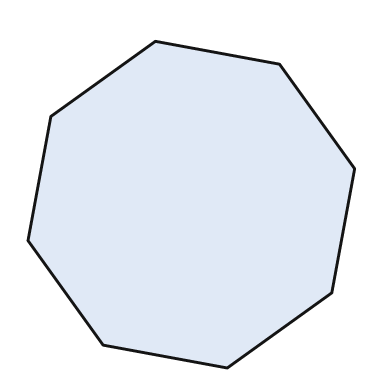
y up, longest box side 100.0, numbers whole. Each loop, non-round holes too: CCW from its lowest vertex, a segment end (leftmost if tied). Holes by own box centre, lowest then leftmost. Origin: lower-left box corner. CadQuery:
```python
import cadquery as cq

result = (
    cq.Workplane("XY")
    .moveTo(61.0, 0.0)
    .lineTo(93.0, 23.0)
    .lineTo(100.0, 61.0)
    .lineTo(77.0, 93.0)
    .lineTo(39.0, 100.0)
    .lineTo(7.0, 77.0)
    .lineTo(0.0, 39.0)
    .lineTo(23.0, 7.0)
    .close()
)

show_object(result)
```